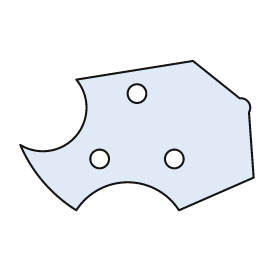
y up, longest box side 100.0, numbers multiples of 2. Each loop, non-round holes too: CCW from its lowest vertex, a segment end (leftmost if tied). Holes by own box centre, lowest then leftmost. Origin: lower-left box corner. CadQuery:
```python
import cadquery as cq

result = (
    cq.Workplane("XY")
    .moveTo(24.0, 0.0)
    .threePointArc((46.0, 12.0), (68.0, 0.0))
    .lineTo(100.0, 14.0)
    .lineTo(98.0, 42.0)
    .threePointArc((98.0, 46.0), (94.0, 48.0))
    .lineTo(74.0, 64.0)
    .lineTo(24.0, 56.0)
    .threePointArc((24.0, 32.0), (0.0, 28.0))
    .threePointArc((10.0, 12.0), (24.0, 0.0))
    .close()
    .moveTo(34.0, 22.0)
    .circle(4.0)
    .moveTo(66.0, 22.0)
    .circle(4.0)
    .moveTo(50.0, 50.0)
    .circle(4.0)
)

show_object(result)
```